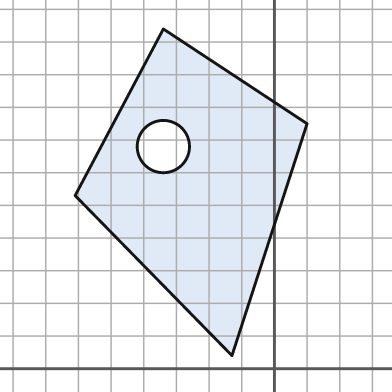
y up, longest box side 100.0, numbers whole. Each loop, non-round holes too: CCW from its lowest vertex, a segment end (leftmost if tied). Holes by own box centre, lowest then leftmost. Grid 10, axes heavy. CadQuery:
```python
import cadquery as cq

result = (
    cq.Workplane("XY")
    .moveTo(-13.0, 4.0)
    .lineTo(10.0, 75.0)
    .lineTo(-34.0, 104.0)
    .lineTo(-61.0, 53.0)
    .close()
    .moveTo(-34.0, 68.0)
    .circle(8.0)
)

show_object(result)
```